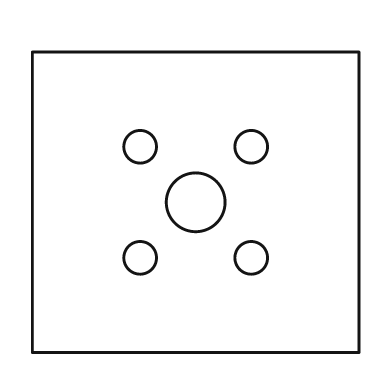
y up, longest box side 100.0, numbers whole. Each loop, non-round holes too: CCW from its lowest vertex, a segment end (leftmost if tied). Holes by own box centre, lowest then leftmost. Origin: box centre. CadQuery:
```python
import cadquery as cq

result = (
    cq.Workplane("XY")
    .moveTo(-50.0, -46.0)
    .lineTo(50.0, -46.0)
    .lineTo(50.0, 46.0)
    .lineTo(-50.0, 46.0)
    .close()
    .moveTo(-17.0, -17.0)
    .circle(5.0)
    .moveTo(17.0, -17.0)
    .circle(5.0)
    .moveTo(0.0, 0.0)
    .circle(9.0)
    .moveTo(-17.0, 17.0)
    .circle(5.0)
    .moveTo(17.0, 17.0)
    .circle(5.0)
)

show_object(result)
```